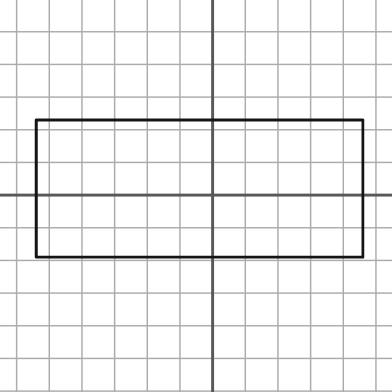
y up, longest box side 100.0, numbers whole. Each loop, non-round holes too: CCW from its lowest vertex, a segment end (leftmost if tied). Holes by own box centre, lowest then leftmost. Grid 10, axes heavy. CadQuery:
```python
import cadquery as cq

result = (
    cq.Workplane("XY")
    .moveTo(-54.0, -19.0)
    .lineTo(46.0, -19.0)
    .lineTo(46.0, 23.0)
    .lineTo(-54.0, 23.0)
    .close()
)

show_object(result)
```